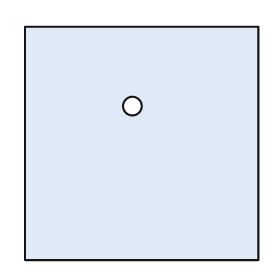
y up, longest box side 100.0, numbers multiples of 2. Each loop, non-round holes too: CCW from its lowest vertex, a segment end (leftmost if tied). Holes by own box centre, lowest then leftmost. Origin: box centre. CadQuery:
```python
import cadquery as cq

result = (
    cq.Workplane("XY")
    .moveTo(-50.0, -50.0)
    .lineTo(50.0, -50.0)
    .lineTo(50.0, 50.0)
    .lineTo(-50.0, 50.0)
    .close()
    .moveTo(-4.0, 16.0)
    .circle(4.0)
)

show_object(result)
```